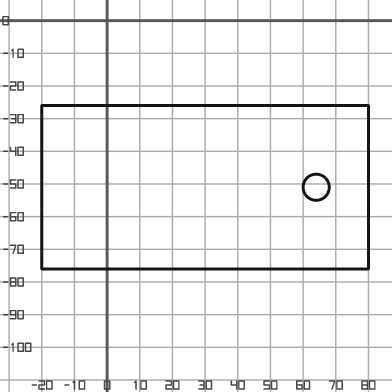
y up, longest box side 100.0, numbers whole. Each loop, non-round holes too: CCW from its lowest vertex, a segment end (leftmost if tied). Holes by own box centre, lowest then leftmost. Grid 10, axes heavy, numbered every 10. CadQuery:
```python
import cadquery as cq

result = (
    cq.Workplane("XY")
    .moveTo(-20.0, -76.0)
    .lineTo(80.0, -76.0)
    .lineTo(80.0, -26.0)
    .lineTo(-20.0, -26.0)
    .close()
    .moveTo(64.0, -51.0)
    .circle(4.0)
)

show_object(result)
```